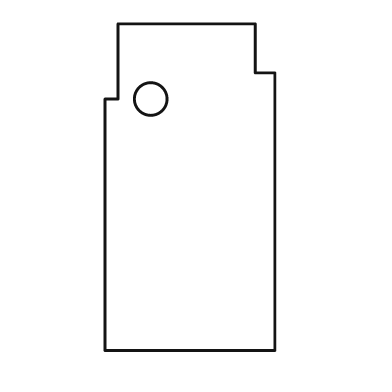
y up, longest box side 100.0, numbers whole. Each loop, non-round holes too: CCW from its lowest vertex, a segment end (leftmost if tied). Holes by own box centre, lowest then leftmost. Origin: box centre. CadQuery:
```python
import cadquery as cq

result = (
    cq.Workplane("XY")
    .moveTo(-26.0, -50.0)
    .lineTo(26.0, -50.0)
    .lineTo(26.0, 35.0)
    .lineTo(20.0, 35.0)
    .lineTo(20.0, 50.0)
    .lineTo(-22.0, 50.0)
    .lineTo(-22.0, 27.0)
    .lineTo(-26.0, 27.0)
    .close()
    .moveTo(-12.0, 27.0)
    .circle(5.0)
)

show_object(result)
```